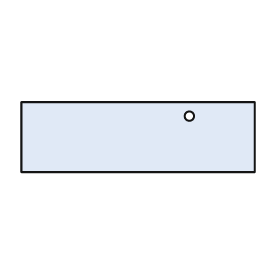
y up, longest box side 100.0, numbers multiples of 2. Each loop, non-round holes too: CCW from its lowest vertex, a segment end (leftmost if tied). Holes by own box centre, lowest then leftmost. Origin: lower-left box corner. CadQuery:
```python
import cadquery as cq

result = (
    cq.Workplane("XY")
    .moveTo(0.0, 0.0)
    .lineTo(100.0, 0.0)
    .lineTo(100.0, 30.0)
    .lineTo(0.0, 30.0)
    .close()
    .moveTo(72.0, 24.0)
    .circle(2.0)
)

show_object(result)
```